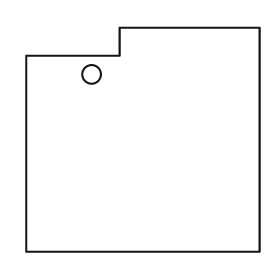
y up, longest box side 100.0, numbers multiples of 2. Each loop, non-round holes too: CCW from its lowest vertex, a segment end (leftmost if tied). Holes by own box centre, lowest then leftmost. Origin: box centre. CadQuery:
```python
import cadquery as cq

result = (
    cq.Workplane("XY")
    .moveTo(-50.0, -48.0)
    .lineTo(50.0, -48.0)
    .lineTo(50.0, 48.0)
    .lineTo(-10.0, 48.0)
    .lineTo(-10.0, 36.0)
    .lineTo(-50.0, 36.0)
    .close()
    .moveTo(-22.0, 28.0)
    .circle(4.0)
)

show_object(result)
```